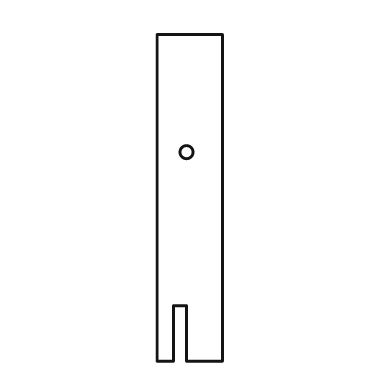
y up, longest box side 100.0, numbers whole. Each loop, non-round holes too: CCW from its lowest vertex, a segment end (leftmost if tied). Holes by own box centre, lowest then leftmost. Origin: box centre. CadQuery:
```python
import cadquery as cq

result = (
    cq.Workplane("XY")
    .moveTo(-10.0, -50.0)
    .lineTo(-5.0, -50.0)
    .lineTo(-5.0, -33.0)
    .lineTo(-1.0, -33.0)
    .lineTo(-1.0, -50.0)
    .lineTo(10.0, -50.0)
    .lineTo(10.0, 50.0)
    .lineTo(-10.0, 50.0)
    .close()
    .moveTo(-1.0, 14.0)
    .circle(2.0)
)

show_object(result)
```